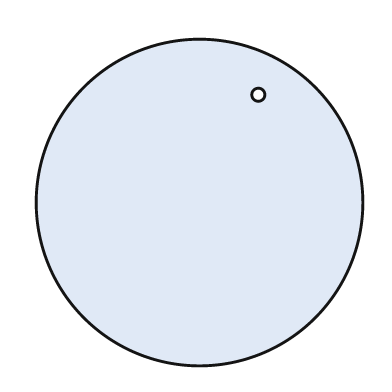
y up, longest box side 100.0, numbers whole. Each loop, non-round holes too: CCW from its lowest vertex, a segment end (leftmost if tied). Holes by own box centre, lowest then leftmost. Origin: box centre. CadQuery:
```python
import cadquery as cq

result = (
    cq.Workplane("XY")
    .moveTo(0.0, 0.0)
    .circle(50.0)
    .moveTo(18.0, 33.0)
    .circle(2.0)
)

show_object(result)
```